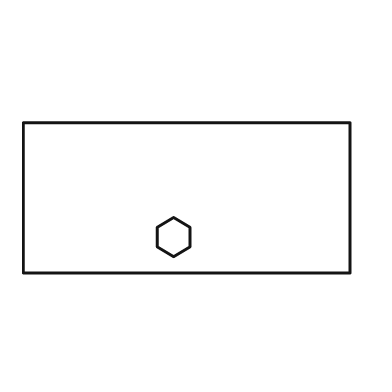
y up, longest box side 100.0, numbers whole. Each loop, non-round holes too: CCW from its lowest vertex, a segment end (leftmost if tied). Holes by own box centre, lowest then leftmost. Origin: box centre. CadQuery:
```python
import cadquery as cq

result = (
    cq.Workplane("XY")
    .moveTo(-50.0, -23.0)
    .lineTo(50.0, -23.0)
    .lineTo(50.0, 23.0)
    .lineTo(-50.0, 23.0)
    .close()
    .moveTo(-4.0, -18.0)
    .lineTo(1.0, -15.0)
    .lineTo(1.0, -9.0)
    .lineTo(-4.0, -6.0)
    .lineTo(-9.0, -9.0)
    .lineTo(-9.0, -15.0)
    .close()
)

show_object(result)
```